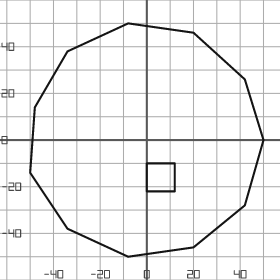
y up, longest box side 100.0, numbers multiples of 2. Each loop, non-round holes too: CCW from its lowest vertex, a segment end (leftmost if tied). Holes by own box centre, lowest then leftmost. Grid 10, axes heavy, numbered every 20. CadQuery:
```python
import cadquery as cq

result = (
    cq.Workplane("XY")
    .moveTo(-8.0, -50.0)
    .lineTo(20.0, -46.0)
    .lineTo(42.0, -28.0)
    .lineTo(50.0, 0.0)
    .lineTo(42.0, 26.0)
    .lineTo(20.0, 46.0)
    .lineTo(-8.0, 50.0)
    .lineTo(-34.0, 38.0)
    .lineTo(-48.0, 14.0)
    .lineTo(-50.0, -14.0)
    .lineTo(-34.0, -38.0)
    .close()
    .moveTo(0.0, -22.0)
    .lineTo(12.0, -22.0)
    .lineTo(12.0, -10.0)
    .lineTo(0.0, -10.0)
    .close()
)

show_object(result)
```